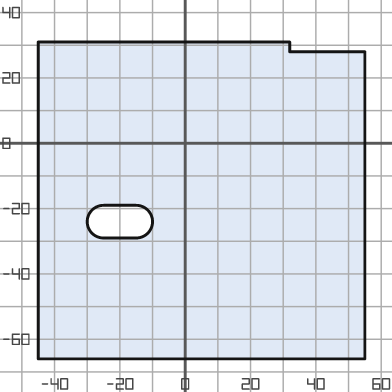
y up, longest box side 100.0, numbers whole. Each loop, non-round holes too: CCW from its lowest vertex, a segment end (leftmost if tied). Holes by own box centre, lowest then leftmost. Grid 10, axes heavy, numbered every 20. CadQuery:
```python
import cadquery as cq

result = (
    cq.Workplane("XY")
    .moveTo(-45.0, -66.0)
    .lineTo(55.0, -66.0)
    .lineTo(55.0, 28.0)
    .lineTo(32.0, 28.0)
    .lineTo(32.0, 31.0)
    .lineTo(-45.0, 31.0)
    .close()
    .moveTo(-25.0, -29.0)
    .lineTo(-15.0, -29.0)
    .threePointArc((-10.0, -24.0), (-15.0, -19.0))
    .lineTo(-25.0, -19.0)
    .threePointArc((-30.0, -24.0), (-25.0, -29.0))
    .close()
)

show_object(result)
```